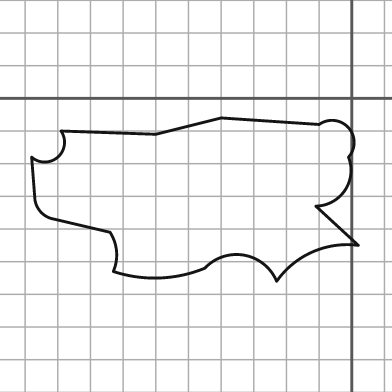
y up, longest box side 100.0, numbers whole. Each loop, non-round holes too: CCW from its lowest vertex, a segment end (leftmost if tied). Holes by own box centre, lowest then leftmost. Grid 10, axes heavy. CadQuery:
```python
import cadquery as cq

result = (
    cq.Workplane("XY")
    .moveTo(-23.0, -56.0)
    .threePointArc((-12.0, -47.0), (2.0, -45.0))
    .lineTo(-11.0, -33.0)
    .threePointArc((-2.0, -28.0), (-1.0, -18.0))
    .threePointArc((-1.0, -9.0), (-10.0, -8.0))
    .lineTo(-40.0, -6.0)
    .lineTo(-60.0, -11.0)
    .lineTo(-89.0, -10.0)
    .threePointArc((-90.0, -18.0), (-98.0, -18.0))
    .lineTo(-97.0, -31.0)
    .threePointArc((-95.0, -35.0), (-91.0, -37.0))
    .lineTo(-74.0, -41.0)
    .threePointArc((-72.0, -47.0), (-73.0, -53.0))
    .threePointArc((-59.0, -55.0), (-45.0, -52.0))
    .threePointArc((-33.0, -48.0), (-23.0, -56.0))
    .close()
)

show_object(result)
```